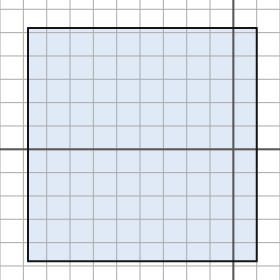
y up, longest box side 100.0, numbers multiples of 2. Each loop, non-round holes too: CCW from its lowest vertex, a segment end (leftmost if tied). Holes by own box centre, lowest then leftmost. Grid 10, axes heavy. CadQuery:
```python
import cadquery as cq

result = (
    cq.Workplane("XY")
    .moveTo(-88.0, -48.0)
    .lineTo(10.0, -48.0)
    .lineTo(10.0, 52.0)
    .lineTo(-88.0, 52.0)
    .close()
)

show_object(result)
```